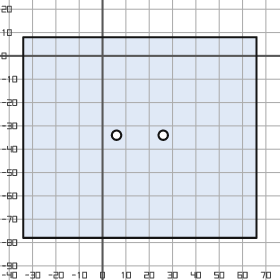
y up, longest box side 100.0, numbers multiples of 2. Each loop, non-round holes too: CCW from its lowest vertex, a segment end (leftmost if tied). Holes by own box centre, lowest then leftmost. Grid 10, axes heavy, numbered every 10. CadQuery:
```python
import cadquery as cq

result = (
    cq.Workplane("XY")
    .moveTo(-34.0, -78.0)
    .lineTo(66.0, -78.0)
    .lineTo(66.0, 8.0)
    .lineTo(-34.0, 8.0)
    .close()
    .moveTo(6.0, -34.0)
    .circle(2.0)
    .moveTo(26.0, -34.0)
    .circle(2.0)
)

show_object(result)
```